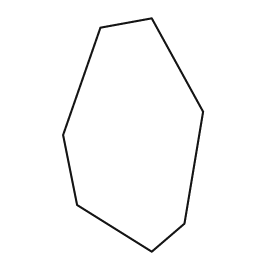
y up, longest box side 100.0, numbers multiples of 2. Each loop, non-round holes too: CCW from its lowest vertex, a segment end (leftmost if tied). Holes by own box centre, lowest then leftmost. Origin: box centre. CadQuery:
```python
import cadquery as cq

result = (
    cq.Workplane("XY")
    .moveTo(8.0, -50.0)
    .lineTo(22.0, -38.0)
    .lineTo(30.0, 10.0)
    .lineTo(8.0, 50.0)
    .lineTo(-14.0, 46.0)
    .lineTo(-30.0, 0.0)
    .lineTo(-24.0, -30.0)
    .close()
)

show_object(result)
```